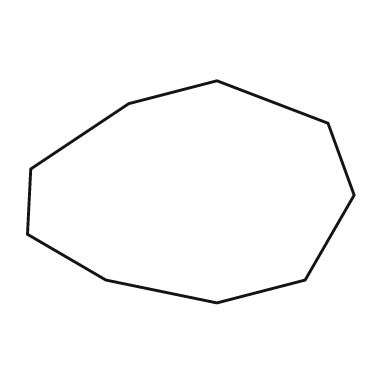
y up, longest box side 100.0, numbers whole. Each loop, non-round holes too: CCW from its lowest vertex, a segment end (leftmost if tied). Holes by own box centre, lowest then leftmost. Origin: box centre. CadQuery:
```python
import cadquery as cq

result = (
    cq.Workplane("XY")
    .moveTo(8.0, -34.0)
    .lineTo(35.0, -27.0)
    .lineTo(50.0, -1.0)
    .lineTo(42.0, 21.0)
    .lineTo(8.0, 34.0)
    .lineTo(-19.0, 27.0)
    .lineTo(-49.0, 7.0)
    .lineTo(-50.0, -13.0)
    .lineTo(-26.0, -27.0)
    .close()
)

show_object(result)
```